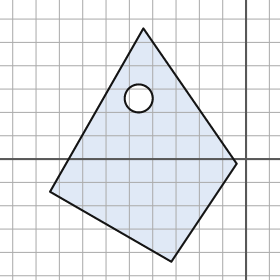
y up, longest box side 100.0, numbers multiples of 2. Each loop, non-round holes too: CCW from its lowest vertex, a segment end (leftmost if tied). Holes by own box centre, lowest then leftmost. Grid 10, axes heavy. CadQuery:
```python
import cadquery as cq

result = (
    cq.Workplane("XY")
    .moveTo(-32.0, -44.0)
    .lineTo(-4.0, -2.0)
    .lineTo(-44.0, 56.0)
    .lineTo(-84.0, -14.0)
    .close()
    .moveTo(-46.0, 26.0)
    .circle(6.0)
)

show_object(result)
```